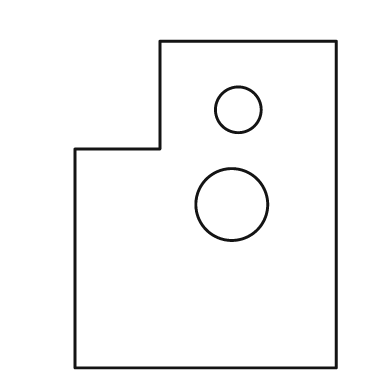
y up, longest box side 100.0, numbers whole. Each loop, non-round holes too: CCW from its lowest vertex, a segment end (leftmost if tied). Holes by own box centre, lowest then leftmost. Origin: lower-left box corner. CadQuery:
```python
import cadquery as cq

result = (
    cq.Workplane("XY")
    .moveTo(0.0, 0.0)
    .lineTo(80.0, 0.0)
    .lineTo(80.0, 100.0)
    .lineTo(26.0, 100.0)
    .lineTo(26.0, 67.0)
    .lineTo(0.0, 67.0)
    .close()
    .moveTo(48.0, 50.0)
    .circle(11.0)
    .moveTo(50.0, 79.0)
    .circle(7.0)
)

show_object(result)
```